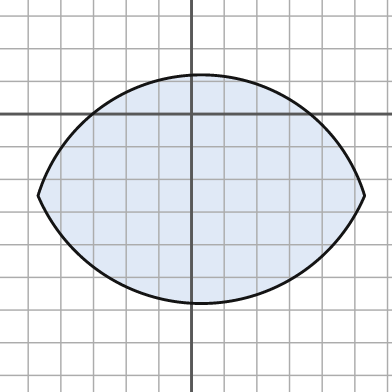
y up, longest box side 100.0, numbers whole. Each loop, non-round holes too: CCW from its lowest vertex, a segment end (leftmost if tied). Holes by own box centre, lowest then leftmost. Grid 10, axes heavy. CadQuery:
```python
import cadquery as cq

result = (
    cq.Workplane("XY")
    .moveTo(-47.0, -25.0)
    .threePointArc((3.0, -58.0), (53.0, -25.0))
    .threePointArc((3.0, 12.0), (-47.0, -25.0))
    .close()
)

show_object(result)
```